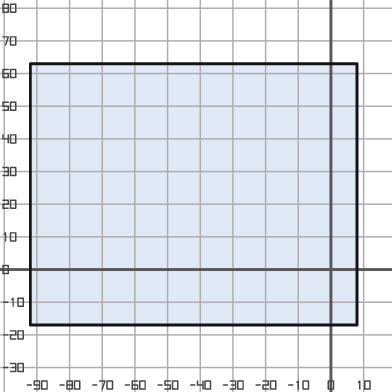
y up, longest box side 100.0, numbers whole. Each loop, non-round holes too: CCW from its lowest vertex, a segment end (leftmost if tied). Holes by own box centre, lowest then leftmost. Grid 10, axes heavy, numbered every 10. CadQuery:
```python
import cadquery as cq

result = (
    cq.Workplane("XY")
    .moveTo(-92.0, -17.0)
    .lineTo(8.0, -17.0)
    .lineTo(8.0, 63.0)
    .lineTo(-92.0, 63.0)
    .close()
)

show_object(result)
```